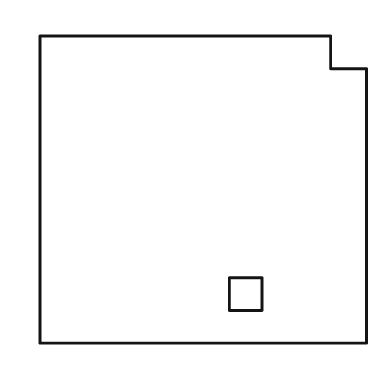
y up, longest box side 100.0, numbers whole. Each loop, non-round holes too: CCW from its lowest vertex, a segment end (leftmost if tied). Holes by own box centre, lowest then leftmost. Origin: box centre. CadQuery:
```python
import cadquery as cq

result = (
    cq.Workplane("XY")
    .moveTo(-50.0, -47.0)
    .lineTo(50.0, -47.0)
    .lineTo(50.0, 37.0)
    .lineTo(39.0, 37.0)
    .lineTo(39.0, 47.0)
    .lineTo(-50.0, 47.0)
    .close()
    .moveTo(8.0, -37.0)
    .lineTo(18.0, -37.0)
    .lineTo(18.0, -27.0)
    .lineTo(8.0, -27.0)
    .close()
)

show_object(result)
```